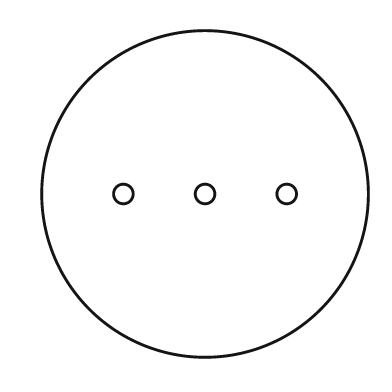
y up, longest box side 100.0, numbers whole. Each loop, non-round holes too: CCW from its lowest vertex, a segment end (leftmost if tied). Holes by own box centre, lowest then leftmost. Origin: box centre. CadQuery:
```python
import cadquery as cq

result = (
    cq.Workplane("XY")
    .moveTo(0.0, 0.0)
    .circle(50.0)
    .moveTo(-25.0, 0.0)
    .circle(3.0)
    .moveTo(0.0, 0.0)
    .circle(3.0)
    .moveTo(25.0, 0.0)
    .circle(3.0)
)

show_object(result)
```